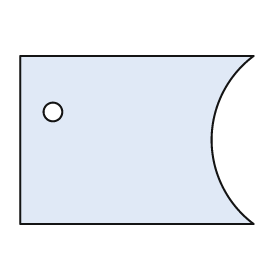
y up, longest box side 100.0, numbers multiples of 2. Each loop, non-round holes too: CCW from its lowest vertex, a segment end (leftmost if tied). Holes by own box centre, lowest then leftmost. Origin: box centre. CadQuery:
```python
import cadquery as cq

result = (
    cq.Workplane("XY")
    .moveTo(-50.0, -36.0)
    .lineTo(50.0, -36.0)
    .threePointArc((32.0, 0.0), (50.0, 36.0))
    .lineTo(-50.0, 36.0)
    .close()
    .moveTo(-36.0, 12.0)
    .circle(4.0)
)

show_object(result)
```